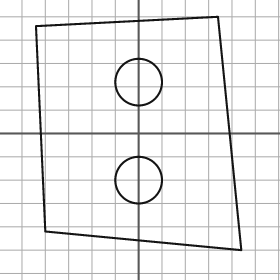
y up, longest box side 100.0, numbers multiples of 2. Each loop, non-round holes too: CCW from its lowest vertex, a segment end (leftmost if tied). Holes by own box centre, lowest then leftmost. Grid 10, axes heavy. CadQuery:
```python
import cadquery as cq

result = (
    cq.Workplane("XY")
    .moveTo(44.0, -50.0)
    .lineTo(34.0, 50.0)
    .lineTo(-44.0, 46.0)
    .lineTo(-40.0, -42.0)
    .close()
    .moveTo(0.0, -20.0)
    .circle(10.0)
    .moveTo(0.0, 22.0)
    .circle(10.0)
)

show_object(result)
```